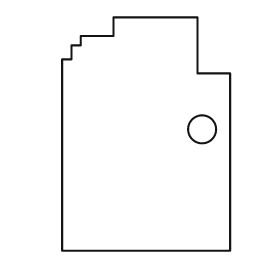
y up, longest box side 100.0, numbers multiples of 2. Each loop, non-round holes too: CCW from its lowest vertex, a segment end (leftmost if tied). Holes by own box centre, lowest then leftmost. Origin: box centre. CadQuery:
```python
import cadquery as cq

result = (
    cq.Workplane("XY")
    .moveTo(-36.0, -50.0)
    .lineTo(36.0, -50.0)
    .lineTo(36.0, 26.0)
    .lineTo(22.0, 26.0)
    .lineTo(22.0, 50.0)
    .lineTo(-14.0, 50.0)
    .lineTo(-14.0, 42.0)
    .lineTo(-28.0, 42.0)
    .lineTo(-28.0, 38.0)
    .lineTo(-32.0, 38.0)
    .lineTo(-32.0, 32.0)
    .lineTo(-36.0, 32.0)
    .close()
    .moveTo(24.0, 2.0)
    .circle(6.0)
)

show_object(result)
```